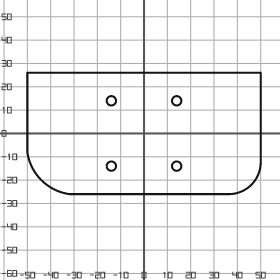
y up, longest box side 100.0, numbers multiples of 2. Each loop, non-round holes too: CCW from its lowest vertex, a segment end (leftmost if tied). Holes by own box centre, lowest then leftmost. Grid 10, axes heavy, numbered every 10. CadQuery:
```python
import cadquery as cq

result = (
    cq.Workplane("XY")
    .moveTo(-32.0, -26.0)
    .lineTo(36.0, -26.0)
    .threePointArc((46.0, -22.0), (50.0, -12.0))
    .lineTo(50.0, 26.0)
    .lineTo(-50.0, 26.0)
    .lineTo(-50.0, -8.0)
    .threePointArc((-44.0, -20.0), (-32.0, -26.0))
    .close()
    .moveTo(-14.0, -14.0)
    .circle(2.0)
    .moveTo(14.0, -14.0)
    .circle(2.0)
    .moveTo(-14.0, 14.0)
    .circle(2.0)
    .moveTo(14.0, 14.0)
    .circle(2.0)
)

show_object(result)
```